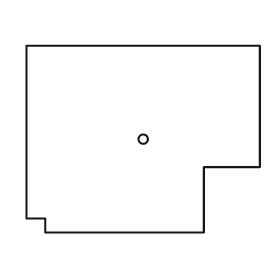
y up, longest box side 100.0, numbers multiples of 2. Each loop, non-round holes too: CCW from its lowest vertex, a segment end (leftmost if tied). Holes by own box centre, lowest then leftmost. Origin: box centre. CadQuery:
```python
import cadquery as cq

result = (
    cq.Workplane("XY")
    .moveTo(-42.0, -40.0)
    .lineTo(26.0, -40.0)
    .lineTo(26.0, -12.0)
    .lineTo(50.0, -12.0)
    .lineTo(50.0, 40.0)
    .lineTo(-50.0, 40.0)
    .lineTo(-50.0, -34.0)
    .lineTo(-42.0, -34.0)
    .close()
    .moveTo(0.0, 0.0)
    .circle(2.0)
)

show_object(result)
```